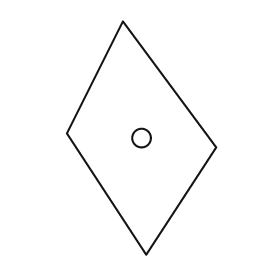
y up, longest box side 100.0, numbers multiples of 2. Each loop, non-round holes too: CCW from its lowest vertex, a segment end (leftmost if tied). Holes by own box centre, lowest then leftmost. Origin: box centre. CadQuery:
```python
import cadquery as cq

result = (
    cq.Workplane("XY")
    .moveTo(2.0, -50.0)
    .lineTo(32.0, -4.0)
    .lineTo(-8.0, 50.0)
    .lineTo(-32.0, 2.0)
    .close()
    .moveTo(0.0, 0.0)
    .circle(4.0)
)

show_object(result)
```